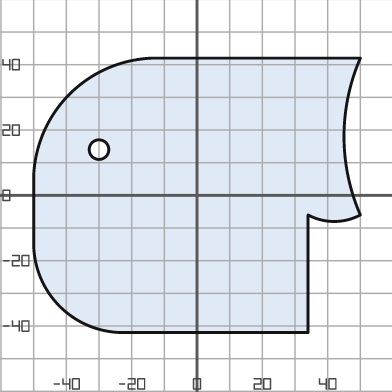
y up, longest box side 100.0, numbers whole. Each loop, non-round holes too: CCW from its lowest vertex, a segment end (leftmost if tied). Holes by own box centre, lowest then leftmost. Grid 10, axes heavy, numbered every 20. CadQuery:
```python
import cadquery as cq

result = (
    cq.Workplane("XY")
    .moveTo(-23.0, -42.0)
    .lineTo(34.0, -42.0)
    .lineTo(34.0, -6.0)
    .threePointArc((42.0, -8.0), (50.0, -6.0))
    .threePointArc((45.0, 18.0), (50.0, 42.0))
    .lineTo(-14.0, 42.0)
    .threePointArc((-39.0, 31.0), (-50.0, 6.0))
    .lineTo(-50.0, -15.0)
    .threePointArc((-42.0, -34.0), (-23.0, -42.0))
    .close()
    .moveTo(-30.0, 14.0)
    .circle(3.0)
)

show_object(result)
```